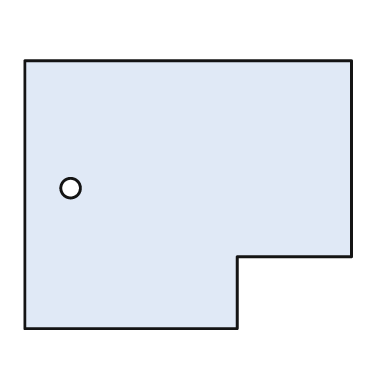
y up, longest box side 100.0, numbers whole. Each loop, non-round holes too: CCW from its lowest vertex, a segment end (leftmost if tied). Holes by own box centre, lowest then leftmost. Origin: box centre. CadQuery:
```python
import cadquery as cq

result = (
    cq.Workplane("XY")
    .moveTo(-50.0, -41.0)
    .lineTo(15.0, -41.0)
    .lineTo(15.0, -19.0)
    .lineTo(50.0, -19.0)
    .lineTo(50.0, 41.0)
    .lineTo(-50.0, 41.0)
    .close()
    .moveTo(-36.0, 2.0)
    .circle(3.0)
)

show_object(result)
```